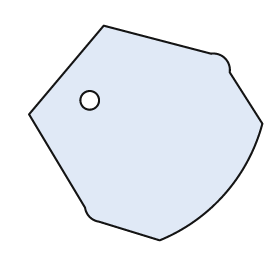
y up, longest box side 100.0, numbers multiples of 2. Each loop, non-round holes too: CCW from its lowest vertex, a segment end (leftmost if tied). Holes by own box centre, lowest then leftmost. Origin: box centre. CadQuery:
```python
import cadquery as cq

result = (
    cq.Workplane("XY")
    .moveTo(6.0, -46.0)
    .threePointArc((34.0, -26.0), (50.0, 4.0))
    .lineTo(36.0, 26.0)
    .threePointArc((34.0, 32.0), (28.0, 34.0))
    .lineTo(-18.0, 46.0)
    .lineTo(-50.0, 8.0)
    .lineTo(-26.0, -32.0)
    .threePointArc((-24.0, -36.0), (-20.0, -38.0))
    .close()
    .moveTo(-24.0, 14.0)
    .circle(4.0)
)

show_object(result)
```